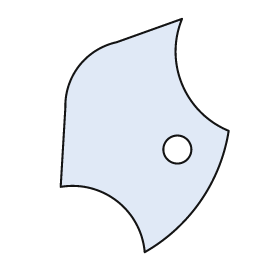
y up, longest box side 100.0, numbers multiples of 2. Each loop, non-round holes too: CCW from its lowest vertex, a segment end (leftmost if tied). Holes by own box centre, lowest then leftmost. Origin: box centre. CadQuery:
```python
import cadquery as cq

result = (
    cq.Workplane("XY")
    .moveTo(0.0, -50.0)
    .threePointArc((24.0, -28.0), (36.0, 2.0))
    .threePointArc((16.0, 22.0), (16.0, 50.0))
    .lineTo(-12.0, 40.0)
    .threePointArc((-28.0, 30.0), (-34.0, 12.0))
    .lineTo(-36.0, -22.0)
    .threePointArc((-12.0, -28.0), (0.0, -50.0))
    .close()
    .moveTo(14.0, -6.0)
    .circle(6.0)
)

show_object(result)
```